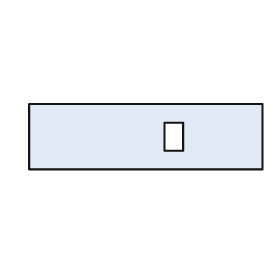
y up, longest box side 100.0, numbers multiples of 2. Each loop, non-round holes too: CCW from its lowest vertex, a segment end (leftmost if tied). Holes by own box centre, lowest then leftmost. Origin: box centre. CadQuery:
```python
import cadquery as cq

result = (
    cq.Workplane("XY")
    .moveTo(-50.0, -14.0)
    .lineTo(50.0, -14.0)
    .lineTo(50.0, 14.0)
    .lineTo(-50.0, 14.0)
    .close()
    .moveTo(8.0, -6.0)
    .lineTo(16.0, -6.0)
    .lineTo(16.0, 6.0)
    .lineTo(8.0, 6.0)
    .close()
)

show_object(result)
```